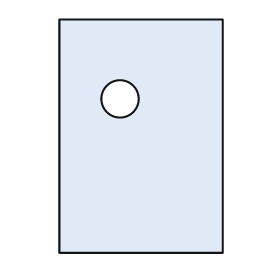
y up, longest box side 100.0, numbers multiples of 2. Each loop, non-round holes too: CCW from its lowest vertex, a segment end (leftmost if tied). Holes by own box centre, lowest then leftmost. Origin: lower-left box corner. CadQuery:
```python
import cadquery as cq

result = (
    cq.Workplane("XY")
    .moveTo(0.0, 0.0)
    .lineTo(70.0, 0.0)
    .lineTo(70.0, 100.0)
    .lineTo(0.0, 100.0)
    .close()
    .moveTo(26.0, 66.0)
    .circle(8.0)
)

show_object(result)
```